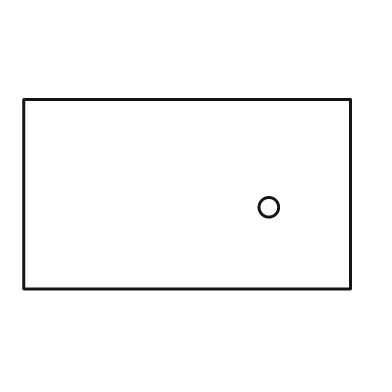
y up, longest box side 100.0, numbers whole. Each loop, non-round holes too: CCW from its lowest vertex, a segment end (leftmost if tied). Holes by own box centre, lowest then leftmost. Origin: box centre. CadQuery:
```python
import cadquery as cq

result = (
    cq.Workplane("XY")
    .moveTo(-50.0, -29.0)
    .lineTo(50.0, -29.0)
    .lineTo(50.0, 29.0)
    .lineTo(-50.0, 29.0)
    .close()
    .moveTo(25.0, -4.0)
    .circle(3.0)
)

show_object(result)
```